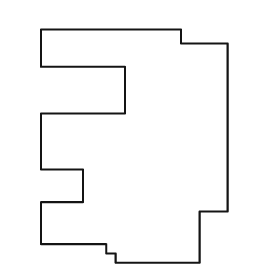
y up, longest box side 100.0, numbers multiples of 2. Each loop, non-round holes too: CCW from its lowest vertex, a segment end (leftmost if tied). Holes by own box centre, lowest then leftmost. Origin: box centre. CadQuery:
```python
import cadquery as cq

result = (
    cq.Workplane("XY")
    .moveTo(-8.0, -50.0)
    .lineTo(28.0, -50.0)
    .lineTo(28.0, -28.0)
    .lineTo(40.0, -28.0)
    .lineTo(40.0, 44.0)
    .lineTo(20.0, 44.0)
    .lineTo(20.0, 50.0)
    .lineTo(-40.0, 50.0)
    .lineTo(-40.0, 34.0)
    .lineTo(-4.0, 34.0)
    .lineTo(-4.0, 14.0)
    .lineTo(-40.0, 14.0)
    .lineTo(-40.0, -10.0)
    .lineTo(-22.0, -10.0)
    .lineTo(-22.0, -24.0)
    .lineTo(-40.0, -24.0)
    .lineTo(-40.0, -42.0)
    .lineTo(-12.0, -42.0)
    .lineTo(-12.0, -46.0)
    .lineTo(-8.0, -46.0)
    .close()
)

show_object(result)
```